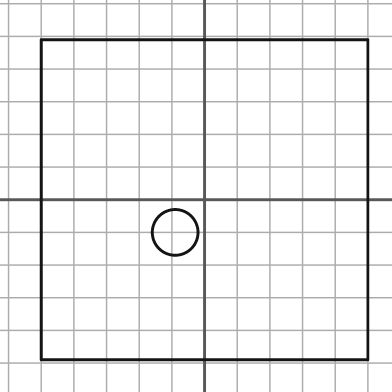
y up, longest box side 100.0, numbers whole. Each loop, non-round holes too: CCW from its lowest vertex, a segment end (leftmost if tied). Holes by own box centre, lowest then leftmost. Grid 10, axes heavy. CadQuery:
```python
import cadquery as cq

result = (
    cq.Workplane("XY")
    .moveTo(-50.0, -49.0)
    .lineTo(50.0, -49.0)
    .lineTo(50.0, 49.0)
    .lineTo(-50.0, 49.0)
    .close()
    .moveTo(-9.0, -10.0)
    .circle(7.0)
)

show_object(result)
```